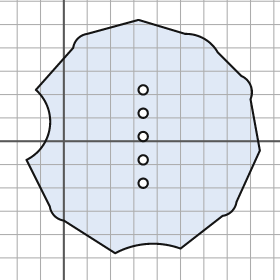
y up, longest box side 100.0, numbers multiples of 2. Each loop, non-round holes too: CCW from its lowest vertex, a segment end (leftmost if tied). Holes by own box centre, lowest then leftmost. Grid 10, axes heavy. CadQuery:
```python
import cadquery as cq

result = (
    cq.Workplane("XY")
    .moveTo(22.0, -48.0)
    .threePointArc((36.0, -44.0), (50.0, -46.0))
    .lineTo(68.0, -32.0)
    .threePointArc((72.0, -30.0), (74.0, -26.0))
    .lineTo(84.0, -4.0)
    .lineTo(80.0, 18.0)
    .threePointArc((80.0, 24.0), (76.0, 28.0))
    .lineTo(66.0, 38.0)
    .threePointArc((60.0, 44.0), (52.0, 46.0))
    .lineTo(32.0, 52.0)
    .lineTo(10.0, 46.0)
    .threePointArc((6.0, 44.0), (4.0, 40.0))
    .lineTo(-12.0, 22.0)
    .threePointArc((-6.0, 6.0), (-16.0, -8.0))
    .lineTo(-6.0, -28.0)
    .threePointArc((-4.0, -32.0), (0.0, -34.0))
    .close()
    .moveTo(34.0, -18.0)
    .circle(2.0)
    .moveTo(34.0, -8.0)
    .circle(2.0)
    .moveTo(34.0, 2.0)
    .circle(2.0)
    .moveTo(34.0, 12.0)
    .circle(2.0)
    .moveTo(34.0, 22.0)
    .circle(2.0)
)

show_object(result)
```